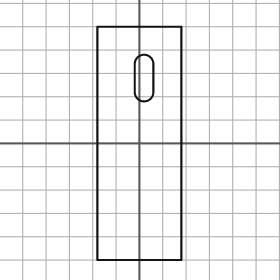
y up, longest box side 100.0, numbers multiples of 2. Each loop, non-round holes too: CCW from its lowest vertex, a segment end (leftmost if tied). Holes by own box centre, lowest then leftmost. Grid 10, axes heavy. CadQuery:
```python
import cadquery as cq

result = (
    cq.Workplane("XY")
    .moveTo(-18.0, -50.0)
    .lineTo(18.0, -50.0)
    .lineTo(18.0, 50.0)
    .lineTo(-18.0, 50.0)
    .close()
    .moveTo(-2.0, 22.0)
    .threePointArc((2.0, 18.0), (6.0, 22.0))
    .lineTo(6.0, 34.0)
    .threePointArc((2.0, 38.0), (-2.0, 34.0))
    .close()
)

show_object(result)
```